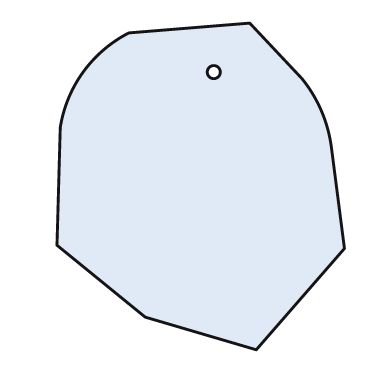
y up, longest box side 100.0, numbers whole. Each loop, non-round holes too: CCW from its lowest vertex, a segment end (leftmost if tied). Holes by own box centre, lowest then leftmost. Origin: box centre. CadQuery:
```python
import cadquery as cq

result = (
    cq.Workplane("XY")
    .moveTo(17.0, -50.0)
    .lineTo(44.0, -19.0)
    .lineTo(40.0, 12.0)
    .threePointArc((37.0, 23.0), (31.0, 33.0))
    .lineTo(15.0, 50.0)
    .lineTo(-22.0, 47.0)
    .threePointArc((-36.0, 35.0), (-43.0, 18.0))
    .lineTo(-44.0, -18.0)
    .lineTo(-17.0, -40.0)
    .close()
    .moveTo(4.0, 35.0)
    .circle(2.0)
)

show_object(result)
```